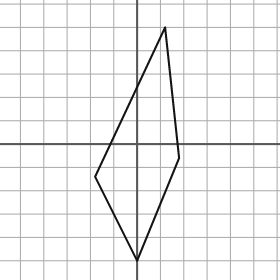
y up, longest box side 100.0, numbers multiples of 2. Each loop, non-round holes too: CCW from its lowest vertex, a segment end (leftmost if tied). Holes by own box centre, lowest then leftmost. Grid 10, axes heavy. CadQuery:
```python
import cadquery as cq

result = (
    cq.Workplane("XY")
    .moveTo(0.0, -50.0)
    .lineTo(18.0, -6.0)
    .lineTo(12.0, 50.0)
    .lineTo(-18.0, -14.0)
    .close()
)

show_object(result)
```